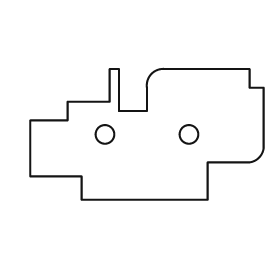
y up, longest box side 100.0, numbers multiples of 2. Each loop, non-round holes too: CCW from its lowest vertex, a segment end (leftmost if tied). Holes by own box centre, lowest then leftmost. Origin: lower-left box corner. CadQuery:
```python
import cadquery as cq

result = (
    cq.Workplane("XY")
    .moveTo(22.0, 0.0)
    .lineTo(76.0, 0.0)
    .lineTo(76.0, 16.0)
    .lineTo(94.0, 16.0)
    .threePointArc((98.0, 18.0), (100.0, 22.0))
    .lineTo(100.0, 48.0)
    .lineTo(94.0, 48.0)
    .lineTo(94.0, 56.0)
    .lineTo(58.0, 56.0)
    .threePointArc((52.0, 54.0), (50.0, 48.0))
    .lineTo(50.0, 38.0)
    .lineTo(38.0, 38.0)
    .lineTo(38.0, 56.0)
    .lineTo(34.0, 56.0)
    .lineTo(34.0, 42.0)
    .lineTo(16.0, 42.0)
    .lineTo(16.0, 34.0)
    .lineTo(0.0, 34.0)
    .lineTo(0.0, 10.0)
    .lineTo(22.0, 10.0)
    .close()
    .moveTo(32.0, 28.0)
    .circle(4.0)
    .moveTo(68.0, 28.0)
    .circle(4.0)
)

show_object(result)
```